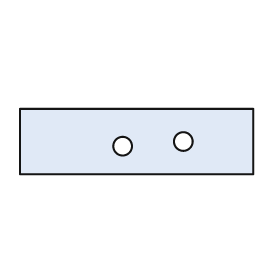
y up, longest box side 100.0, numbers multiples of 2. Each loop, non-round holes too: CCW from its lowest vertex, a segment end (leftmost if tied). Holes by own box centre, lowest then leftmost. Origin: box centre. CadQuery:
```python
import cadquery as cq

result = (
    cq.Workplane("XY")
    .moveTo(-50.0, -14.0)
    .lineTo(50.0, -14.0)
    .lineTo(50.0, 14.0)
    .lineTo(-50.0, 14.0)
    .close()
    .moveTo(-6.0, -2.0)
    .circle(4.0)
    .moveTo(20.0, 0.0)
    .circle(4.0)
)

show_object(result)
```